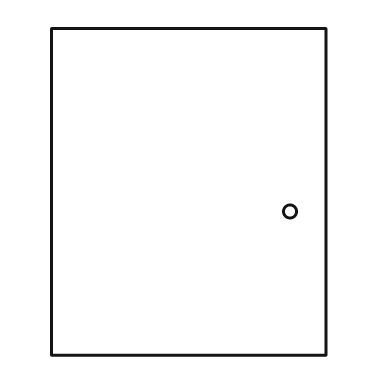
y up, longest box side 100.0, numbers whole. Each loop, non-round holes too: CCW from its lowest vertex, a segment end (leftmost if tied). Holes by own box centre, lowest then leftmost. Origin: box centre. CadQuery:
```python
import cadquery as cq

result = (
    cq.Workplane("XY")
    .moveTo(-42.0, -50.0)
    .lineTo(42.0, -50.0)
    .lineTo(42.0, 50.0)
    .lineTo(-42.0, 50.0)
    .close()
    .moveTo(31.0, -6.0)
    .circle(2.0)
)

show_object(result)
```